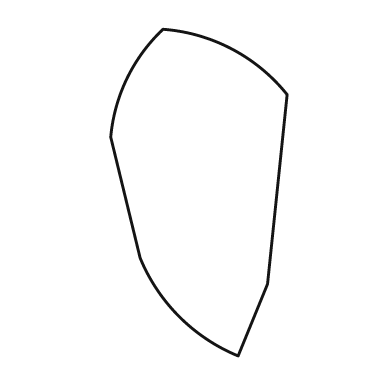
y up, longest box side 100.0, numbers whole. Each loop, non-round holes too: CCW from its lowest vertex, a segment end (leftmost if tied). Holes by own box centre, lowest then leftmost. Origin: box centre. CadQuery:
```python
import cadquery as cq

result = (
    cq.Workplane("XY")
    .moveTo(12.0, -50.0)
    .lineTo(21.0, -28.0)
    .lineTo(27.0, 30.0)
    .threePointArc((10.0, 44.0), (-11.0, 50.0))
    .threePointArc((-22.0, 35.0), (-27.0, 17.0))
    .lineTo(-18.0, -20.0)
    .threePointArc((-6.0, -38.0), (12.0, -50.0))
    .close()
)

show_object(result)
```